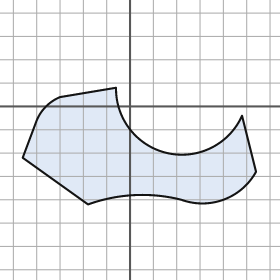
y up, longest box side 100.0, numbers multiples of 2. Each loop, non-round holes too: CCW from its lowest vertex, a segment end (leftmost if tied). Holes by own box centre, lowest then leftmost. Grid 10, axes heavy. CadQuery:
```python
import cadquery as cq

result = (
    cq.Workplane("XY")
    .moveTo(-18.0, -42.0)
    .threePointArc((2.0, -38.0), (22.0, -40.0))
    .threePointArc((40.0, -40.0), (54.0, -28.0))
    .lineTo(48.0, -4.0)
    .threePointArc((16.0, -20.0), (-6.0, 8.0))
    .lineTo(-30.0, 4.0)
    .threePointArc((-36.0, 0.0), (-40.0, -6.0))
    .lineTo(-46.0, -22.0)
    .close()
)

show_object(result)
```